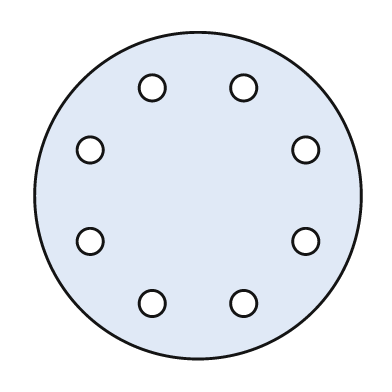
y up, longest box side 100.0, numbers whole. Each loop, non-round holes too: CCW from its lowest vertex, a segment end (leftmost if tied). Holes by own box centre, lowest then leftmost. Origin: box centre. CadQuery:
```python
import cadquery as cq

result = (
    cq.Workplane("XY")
    .moveTo(0.0, 0.0)
    .circle(50.0)
    .moveTo(-14.0, -33.0)
    .circle(4.0)
    .moveTo(14.0, -33.0)
    .circle(4.0)
    .moveTo(-33.0, -14.0)
    .circle(4.0)
    .moveTo(33.0, -14.0)
    .circle(4.0)
    .moveTo(-33.0, 14.0)
    .circle(4.0)
    .moveTo(33.0, 14.0)
    .circle(4.0)
    .moveTo(-14.0, 33.0)
    .circle(4.0)
    .moveTo(14.0, 33.0)
    .circle(4.0)
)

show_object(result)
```